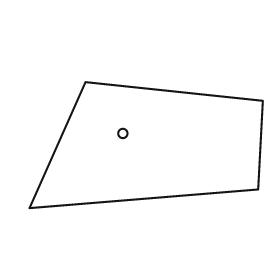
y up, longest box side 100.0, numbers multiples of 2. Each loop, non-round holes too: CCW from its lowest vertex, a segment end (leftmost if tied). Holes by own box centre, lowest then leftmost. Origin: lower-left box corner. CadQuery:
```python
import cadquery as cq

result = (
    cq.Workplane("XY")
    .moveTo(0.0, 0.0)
    .lineTo(98.0, 8.0)
    .lineTo(100.0, 46.0)
    .lineTo(24.0, 54.0)
    .close()
    .moveTo(40.0, 32.0)
    .circle(2.0)
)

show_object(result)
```